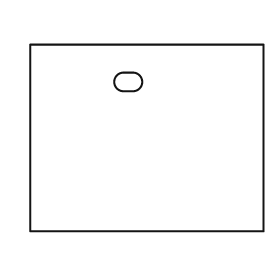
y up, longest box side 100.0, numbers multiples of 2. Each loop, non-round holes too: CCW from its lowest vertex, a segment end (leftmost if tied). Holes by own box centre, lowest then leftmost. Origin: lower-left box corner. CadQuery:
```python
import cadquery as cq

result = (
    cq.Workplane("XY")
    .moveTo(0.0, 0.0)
    .lineTo(100.0, 0.0)
    .lineTo(100.0, 80.0)
    .lineTo(0.0, 80.0)
    .close()
    .moveTo(40.0, 60.0)
    .lineTo(44.0, 60.0)
    .threePointArc((48.0, 64.0), (44.0, 68.0))
    .lineTo(40.0, 68.0)
    .threePointArc((36.0, 64.0), (40.0, 60.0))
    .close()
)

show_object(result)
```